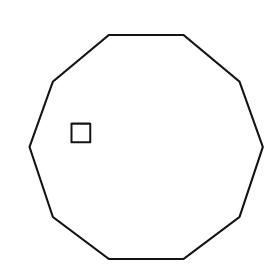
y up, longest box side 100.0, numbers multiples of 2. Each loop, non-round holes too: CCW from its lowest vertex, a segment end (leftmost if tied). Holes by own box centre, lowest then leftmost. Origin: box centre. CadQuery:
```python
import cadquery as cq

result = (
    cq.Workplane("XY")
    .moveTo(-16.0, -48.0)
    .lineTo(16.0, -48.0)
    .lineTo(40.0, -30.0)
    .lineTo(50.0, 0.0)
    .lineTo(40.0, 28.0)
    .lineTo(16.0, 48.0)
    .lineTo(-16.0, 48.0)
    .lineTo(-40.0, 28.0)
    .lineTo(-50.0, 0.0)
    .lineTo(-40.0, -30.0)
    .close()
    .moveTo(-32.0, 2.0)
    .lineTo(-24.0, 2.0)
    .lineTo(-24.0, 10.0)
    .lineTo(-32.0, 10.0)
    .close()
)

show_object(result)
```